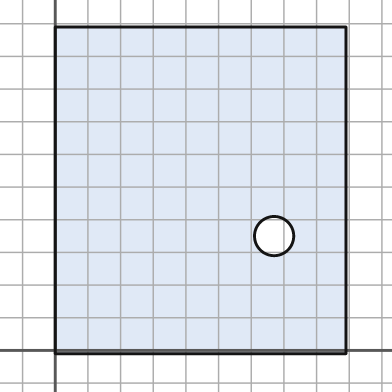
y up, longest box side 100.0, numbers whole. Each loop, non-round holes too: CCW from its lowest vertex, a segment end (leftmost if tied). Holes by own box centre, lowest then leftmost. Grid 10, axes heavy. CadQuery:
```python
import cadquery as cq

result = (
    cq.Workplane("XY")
    .moveTo(0.0, -1.0)
    .lineTo(89.0, -1.0)
    .lineTo(89.0, 99.0)
    .lineTo(0.0, 99.0)
    .close()
    .moveTo(67.0, 35.0)
    .circle(6.0)
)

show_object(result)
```